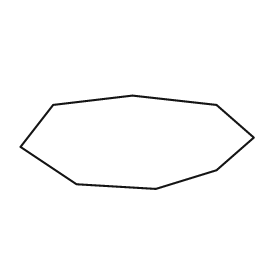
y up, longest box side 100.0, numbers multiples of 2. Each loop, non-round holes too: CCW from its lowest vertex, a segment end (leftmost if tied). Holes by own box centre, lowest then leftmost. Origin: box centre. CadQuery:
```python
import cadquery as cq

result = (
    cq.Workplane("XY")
    .moveTo(8.0, -20.0)
    .lineTo(34.0, -12.0)
    .lineTo(50.0, 2.0)
    .lineTo(34.0, 16.0)
    .lineTo(-2.0, 20.0)
    .lineTo(-36.0, 16.0)
    .lineTo(-50.0, -2.0)
    .lineTo(-26.0, -18.0)
    .close()
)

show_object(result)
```